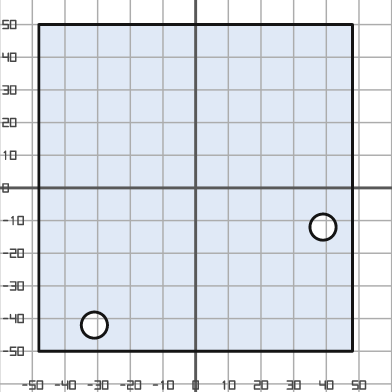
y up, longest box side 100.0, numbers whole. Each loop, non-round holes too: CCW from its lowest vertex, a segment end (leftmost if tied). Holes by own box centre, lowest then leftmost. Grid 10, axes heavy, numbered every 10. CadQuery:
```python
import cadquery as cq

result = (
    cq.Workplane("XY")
    .moveTo(-48.0, -50.0)
    .lineTo(48.0, -50.0)
    .lineTo(48.0, 50.0)
    .lineTo(-48.0, 50.0)
    .close()
    .moveTo(-31.0, -42.0)
    .circle(4.0)
    .moveTo(39.0, -12.0)
    .circle(4.0)
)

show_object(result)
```